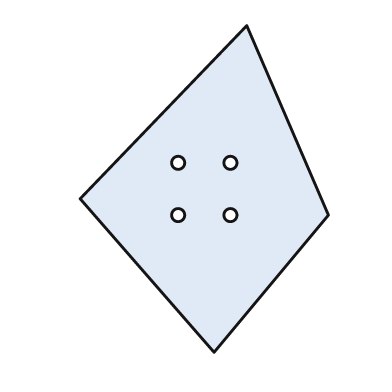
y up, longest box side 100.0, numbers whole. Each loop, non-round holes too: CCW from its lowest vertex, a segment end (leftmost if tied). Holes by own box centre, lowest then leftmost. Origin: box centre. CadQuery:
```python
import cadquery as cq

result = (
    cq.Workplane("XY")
    .moveTo(3.0, -50.0)
    .lineTo(38.0, -8.0)
    .lineTo(13.0, 50.0)
    .lineTo(-38.0, -3.0)
    .close()
    .moveTo(-8.0, -8.0)
    .circle(2.0)
    .moveTo(8.0, -8.0)
    .circle(2.0)
    .moveTo(-8.0, 8.0)
    .circle(2.0)
    .moveTo(8.0, 8.0)
    .circle(2.0)
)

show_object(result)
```